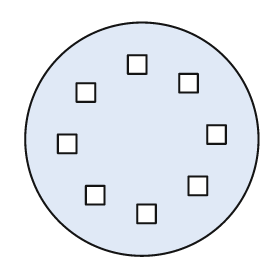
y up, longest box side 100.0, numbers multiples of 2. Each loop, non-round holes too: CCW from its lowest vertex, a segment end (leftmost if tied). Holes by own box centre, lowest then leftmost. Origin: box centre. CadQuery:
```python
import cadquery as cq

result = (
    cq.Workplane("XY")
    .moveTo(0.0, 0.0)
    .circle(50.0)
    .moveTo(-2.0, -36.0)
    .lineTo(6.0, -36.0)
    .lineTo(6.0, -28.0)
    .lineTo(-2.0, -28.0)
    .close()
    .moveTo(-24.0, -28.0)
    .lineTo(-16.0, -28.0)
    .lineTo(-16.0, -20.0)
    .lineTo(-24.0, -20.0)
    .close()
    .moveTo(20.0, -24.0)
    .lineTo(28.0, -24.0)
    .lineTo(28.0, -16.0)
    .lineTo(20.0, -16.0)
    .close()
    .moveTo(-36.0, -6.0)
    .lineTo(-28.0, -6.0)
    .lineTo(-28.0, 2.0)
    .lineTo(-36.0, 2.0)
    .close()
    .moveTo(28.0, -2.0)
    .lineTo(36.0, -2.0)
    .lineTo(36.0, 6.0)
    .lineTo(28.0, 6.0)
    .close()
    .moveTo(-28.0, 16.0)
    .lineTo(-20.0, 16.0)
    .lineTo(-20.0, 24.0)
    .lineTo(-28.0, 24.0)
    .close()
    .moveTo(16.0, 20.0)
    .lineTo(24.0, 20.0)
    .lineTo(24.0, 28.0)
    .lineTo(16.0, 28.0)
    .close()
    .moveTo(-6.0, 28.0)
    .lineTo(2.0, 28.0)
    .lineTo(2.0, 36.0)
    .lineTo(-6.0, 36.0)
    .close()
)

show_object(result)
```